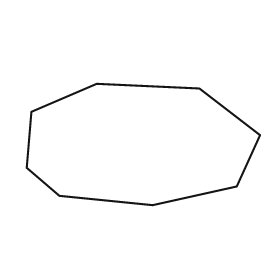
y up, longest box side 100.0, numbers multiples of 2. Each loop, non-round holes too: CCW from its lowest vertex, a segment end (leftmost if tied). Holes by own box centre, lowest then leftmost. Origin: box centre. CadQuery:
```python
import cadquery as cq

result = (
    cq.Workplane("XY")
    .moveTo(4.0, -26.0)
    .lineTo(40.0, -18.0)
    .lineTo(50.0, 4.0)
    .lineTo(24.0, 24.0)
    .lineTo(-20.0, 26.0)
    .lineTo(-48.0, 14.0)
    .lineTo(-50.0, -10.0)
    .lineTo(-36.0, -22.0)
    .close()
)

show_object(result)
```